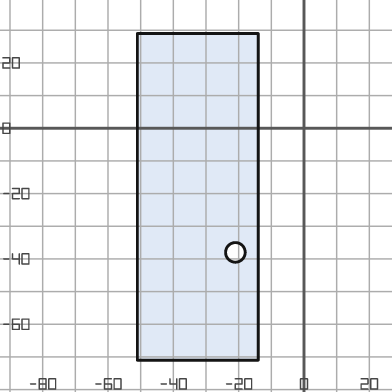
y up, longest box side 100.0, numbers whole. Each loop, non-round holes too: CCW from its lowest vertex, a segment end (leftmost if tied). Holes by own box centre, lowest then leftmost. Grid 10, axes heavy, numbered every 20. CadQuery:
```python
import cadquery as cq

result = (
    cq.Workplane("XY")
    .moveTo(-51.0, -71.0)
    .lineTo(-14.0, -71.0)
    .lineTo(-14.0, 29.0)
    .lineTo(-51.0, 29.0)
    .close()
    .moveTo(-21.0, -38.0)
    .circle(3.0)
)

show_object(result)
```